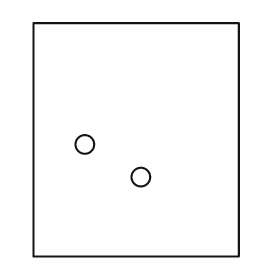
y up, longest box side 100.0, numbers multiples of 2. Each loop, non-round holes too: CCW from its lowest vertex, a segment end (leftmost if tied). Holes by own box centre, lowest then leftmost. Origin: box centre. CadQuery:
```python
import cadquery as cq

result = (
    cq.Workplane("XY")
    .moveTo(-44.0, -50.0)
    .lineTo(44.0, -50.0)
    .lineTo(44.0, 50.0)
    .lineTo(-44.0, 50.0)
    .close()
    .moveTo(2.0, -16.0)
    .circle(4.0)
    .moveTo(-22.0, -2.0)
    .circle(4.0)
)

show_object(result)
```